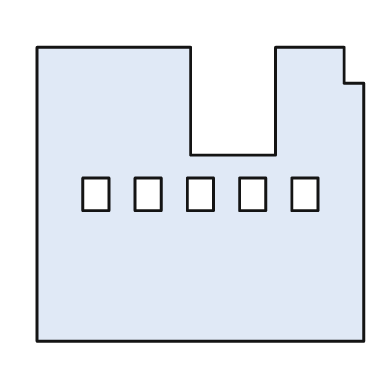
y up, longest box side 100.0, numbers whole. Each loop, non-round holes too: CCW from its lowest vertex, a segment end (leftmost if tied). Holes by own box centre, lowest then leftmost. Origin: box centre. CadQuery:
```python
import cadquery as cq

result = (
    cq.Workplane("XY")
    .moveTo(-50.0, -45.0)
    .lineTo(50.0, -45.0)
    .lineTo(50.0, 34.0)
    .lineTo(44.0, 34.0)
    .lineTo(44.0, 45.0)
    .lineTo(23.0, 45.0)
    .lineTo(23.0, 12.0)
    .lineTo(-3.0, 12.0)
    .lineTo(-3.0, 45.0)
    .lineTo(-50.0, 45.0)
    .close()
    .moveTo(-36.0, -5.0)
    .lineTo(-28.0, -5.0)
    .lineTo(-28.0, 5.0)
    .lineTo(-36.0, 5.0)
    .close()
    .moveTo(-20.0, -5.0)
    .lineTo(-12.0, -5.0)
    .lineTo(-12.0, 5.0)
    .lineTo(-20.0, 5.0)
    .close()
    .moveTo(-4.0, -5.0)
    .lineTo(4.0, -5.0)
    .lineTo(4.0, 5.0)
    .lineTo(-4.0, 5.0)
    .close()
    .moveTo(12.0, -5.0)
    .lineTo(20.0, -5.0)
    .lineTo(20.0, 5.0)
    .lineTo(12.0, 5.0)
    .close()
    .moveTo(28.0, -5.0)
    .lineTo(36.0, -5.0)
    .lineTo(36.0, 5.0)
    .lineTo(28.0, 5.0)
    .close()
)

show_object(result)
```